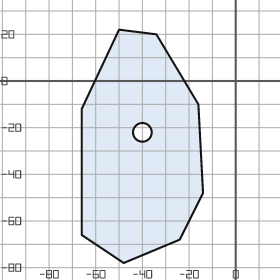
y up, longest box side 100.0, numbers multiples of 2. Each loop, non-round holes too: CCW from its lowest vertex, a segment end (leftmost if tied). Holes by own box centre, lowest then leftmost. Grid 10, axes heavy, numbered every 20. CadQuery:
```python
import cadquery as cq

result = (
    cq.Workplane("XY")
    .moveTo(-48.0, -78.0)
    .lineTo(-24.0, -68.0)
    .lineTo(-14.0, -48.0)
    .lineTo(-16.0, -10.0)
    .lineTo(-34.0, 20.0)
    .lineTo(-50.0, 22.0)
    .lineTo(-66.0, -12.0)
    .lineTo(-66.0, -66.0)
    .close()
    .moveTo(-40.0, -22.0)
    .circle(4.0)
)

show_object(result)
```